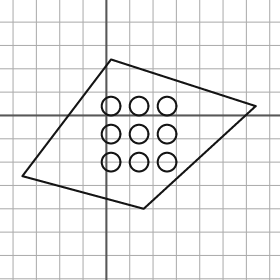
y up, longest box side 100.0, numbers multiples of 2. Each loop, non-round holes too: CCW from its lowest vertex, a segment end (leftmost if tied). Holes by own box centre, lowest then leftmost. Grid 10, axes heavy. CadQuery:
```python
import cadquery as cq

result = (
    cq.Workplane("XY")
    .moveTo(16.0, -40.0)
    .lineTo(64.0, 4.0)
    .lineTo(2.0, 24.0)
    .lineTo(-36.0, -26.0)
    .close()
    .moveTo(2.0, -20.0)
    .circle(4.0)
    .moveTo(14.0, -20.0)
    .circle(4.0)
    .moveTo(26.0, -20.0)
    .circle(4.0)
    .moveTo(2.0, -8.0)
    .circle(4.0)
    .moveTo(14.0, -8.0)
    .circle(4.0)
    .moveTo(26.0, -8.0)
    .circle(4.0)
    .moveTo(2.0, 4.0)
    .circle(4.0)
    .moveTo(14.0, 4.0)
    .circle(4.0)
    .moveTo(26.0, 4.0)
    .circle(4.0)
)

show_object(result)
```